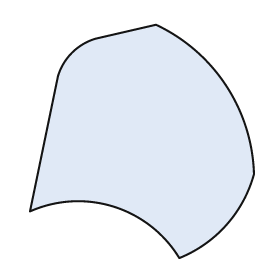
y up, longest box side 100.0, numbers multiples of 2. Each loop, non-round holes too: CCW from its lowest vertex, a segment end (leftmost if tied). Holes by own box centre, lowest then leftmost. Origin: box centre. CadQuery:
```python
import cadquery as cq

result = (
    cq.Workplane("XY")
    .moveTo(16.0, -50.0)
    .threePointArc((36.0, -36.0), (48.0, -14.0))
    .threePointArc((36.0, 24.0), (6.0, 50.0))
    .lineTo(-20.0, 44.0)
    .threePointArc((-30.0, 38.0), (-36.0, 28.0))
    .lineTo(-48.0, -30.0)
    .threePointArc((-12.0, -28.0), (16.0, -50.0))
    .close()
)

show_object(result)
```